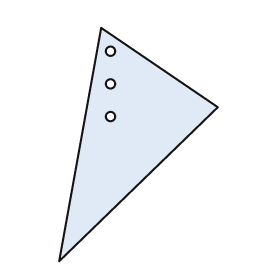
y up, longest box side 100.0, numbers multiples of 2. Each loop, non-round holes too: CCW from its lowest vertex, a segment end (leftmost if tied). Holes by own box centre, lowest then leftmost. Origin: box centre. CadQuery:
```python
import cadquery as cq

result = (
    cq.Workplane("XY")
    .moveTo(-34.0, -50.0)
    .lineTo(34.0, 16.0)
    .lineTo(-16.0, 50.0)
    .close()
    .moveTo(-12.0, 12.0)
    .circle(2.0)
    .moveTo(-12.0, 26.0)
    .circle(2.0)
    .moveTo(-12.0, 40.0)
    .circle(2.0)
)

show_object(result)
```